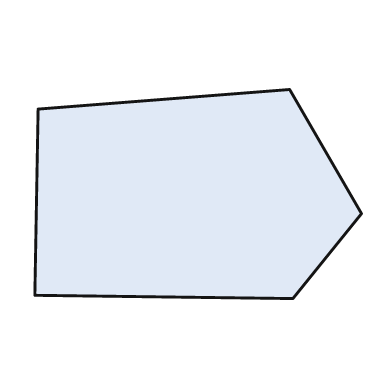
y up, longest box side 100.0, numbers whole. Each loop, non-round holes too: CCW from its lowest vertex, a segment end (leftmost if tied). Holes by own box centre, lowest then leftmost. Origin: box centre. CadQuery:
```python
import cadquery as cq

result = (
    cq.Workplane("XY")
    .moveTo(29.0, -32.0)
    .lineTo(50.0, -6.0)
    .lineTo(28.0, 32.0)
    .lineTo(-49.0, 26.0)
    .lineTo(-50.0, -31.0)
    .close()
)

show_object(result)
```